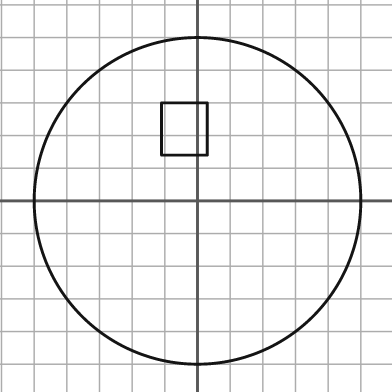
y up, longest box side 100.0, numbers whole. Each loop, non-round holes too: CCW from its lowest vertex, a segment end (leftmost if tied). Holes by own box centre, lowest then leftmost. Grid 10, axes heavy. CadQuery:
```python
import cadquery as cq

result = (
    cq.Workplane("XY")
    .moveTo(0.0, 0.0)
    .circle(50.0)
    .moveTo(-11.0, 14.0)
    .lineTo(3.0, 14.0)
    .lineTo(3.0, 30.0)
    .lineTo(-11.0, 30.0)
    .close()
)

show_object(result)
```